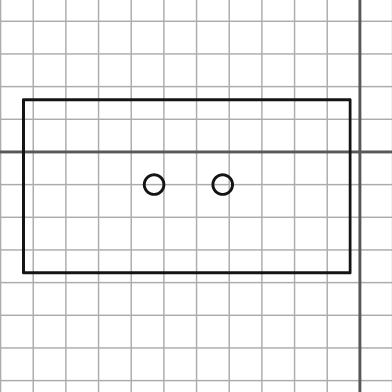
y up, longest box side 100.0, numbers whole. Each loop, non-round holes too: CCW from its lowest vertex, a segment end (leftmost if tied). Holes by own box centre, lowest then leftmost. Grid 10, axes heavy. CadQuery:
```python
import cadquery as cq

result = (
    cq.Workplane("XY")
    .moveTo(-103.0, -37.0)
    .lineTo(-3.0, -37.0)
    .lineTo(-3.0, 16.0)
    .lineTo(-103.0, 16.0)
    .close()
    .moveTo(-63.0, -10.0)
    .circle(3.0)
    .moveTo(-42.0, -10.0)
    .circle(3.0)
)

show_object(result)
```